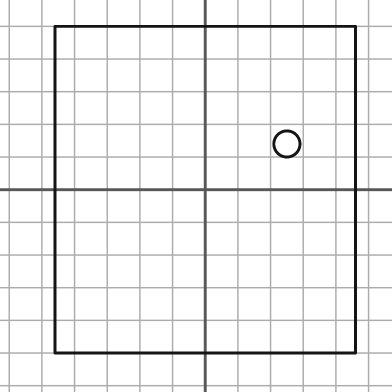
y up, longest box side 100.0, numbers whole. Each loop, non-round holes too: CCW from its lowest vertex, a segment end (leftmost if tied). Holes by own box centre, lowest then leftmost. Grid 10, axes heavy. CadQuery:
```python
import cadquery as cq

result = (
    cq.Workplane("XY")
    .moveTo(-46.0, -50.0)
    .lineTo(46.0, -50.0)
    .lineTo(46.0, 50.0)
    .lineTo(-46.0, 50.0)
    .close()
    .moveTo(25.0, 14.0)
    .circle(4.0)
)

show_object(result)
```